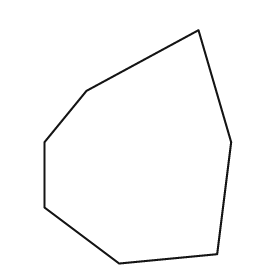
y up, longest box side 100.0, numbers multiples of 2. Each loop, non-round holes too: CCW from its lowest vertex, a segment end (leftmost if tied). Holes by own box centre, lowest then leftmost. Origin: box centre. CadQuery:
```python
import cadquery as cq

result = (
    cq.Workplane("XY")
    .moveTo(-8.0, -50.0)
    .lineTo(34.0, -46.0)
    .lineTo(40.0, 2.0)
    .lineTo(26.0, 50.0)
    .lineTo(-22.0, 24.0)
    .lineTo(-40.0, 2.0)
    .lineTo(-40.0, -26.0)
    .close()
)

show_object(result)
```